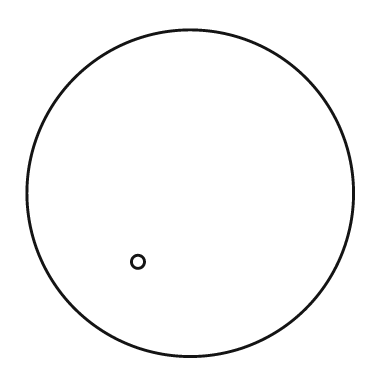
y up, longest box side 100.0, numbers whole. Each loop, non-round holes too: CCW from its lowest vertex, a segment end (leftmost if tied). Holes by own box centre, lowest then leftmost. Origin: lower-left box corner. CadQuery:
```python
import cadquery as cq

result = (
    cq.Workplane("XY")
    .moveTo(50.0, 50.0)
    .circle(50.0)
    .moveTo(34.0, 29.0)
    .circle(2.0)
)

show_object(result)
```